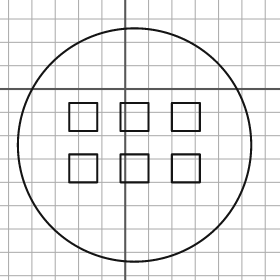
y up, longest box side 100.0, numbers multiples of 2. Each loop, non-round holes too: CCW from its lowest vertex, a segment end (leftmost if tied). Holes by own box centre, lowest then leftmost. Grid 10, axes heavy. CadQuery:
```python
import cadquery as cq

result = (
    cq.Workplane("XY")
    .moveTo(4.0, -24.0)
    .circle(50.0)
    .moveTo(-24.0, -40.0)
    .lineTo(-12.0, -40.0)
    .lineTo(-12.0, -28.0)
    .lineTo(-24.0, -28.0)
    .close()
    .moveTo(-2.0, -40.0)
    .lineTo(10.0, -40.0)
    .lineTo(10.0, -28.0)
    .lineTo(-2.0, -28.0)
    .close()
    .moveTo(20.0, -40.0)
    .lineTo(32.0, -40.0)
    .lineTo(32.0, -28.0)
    .lineTo(20.0, -28.0)
    .close()
    .moveTo(-24.0, -18.0)
    .lineTo(-12.0, -18.0)
    .lineTo(-12.0, -6.0)
    .lineTo(-24.0, -6.0)
    .close()
    .moveTo(-2.0, -18.0)
    .lineTo(10.0, -18.0)
    .lineTo(10.0, -6.0)
    .lineTo(-2.0, -6.0)
    .close()
    .moveTo(20.0, -18.0)
    .lineTo(32.0, -18.0)
    .lineTo(32.0, -6.0)
    .lineTo(20.0, -6.0)
    .close()
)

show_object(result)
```